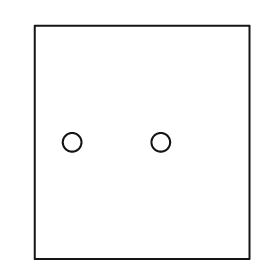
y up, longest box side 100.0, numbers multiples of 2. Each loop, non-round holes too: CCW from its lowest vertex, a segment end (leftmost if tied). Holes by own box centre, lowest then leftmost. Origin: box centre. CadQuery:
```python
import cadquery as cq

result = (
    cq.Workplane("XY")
    .moveTo(-46.0, -50.0)
    .lineTo(46.0, -50.0)
    .lineTo(46.0, 50.0)
    .lineTo(-46.0, 50.0)
    .close()
    .moveTo(-30.0, 0.0)
    .circle(4.0)
    .moveTo(8.0, 0.0)
    .circle(4.0)
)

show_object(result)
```